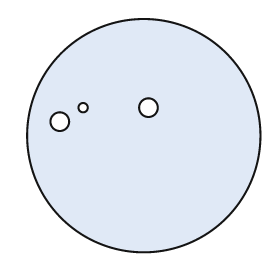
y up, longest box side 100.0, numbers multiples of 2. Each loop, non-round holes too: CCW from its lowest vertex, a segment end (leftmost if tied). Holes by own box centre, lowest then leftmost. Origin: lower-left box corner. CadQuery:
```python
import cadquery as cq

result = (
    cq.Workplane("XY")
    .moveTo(50.0, 50.0)
    .circle(50.0)
    .moveTo(14.0, 56.0)
    .circle(4.0)
    .moveTo(24.0, 62.0)
    .circle(2.0)
    .moveTo(52.0, 62.0)
    .circle(4.0)
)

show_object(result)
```